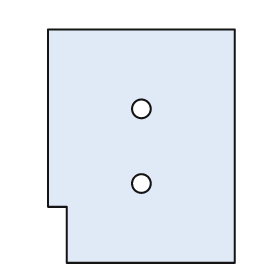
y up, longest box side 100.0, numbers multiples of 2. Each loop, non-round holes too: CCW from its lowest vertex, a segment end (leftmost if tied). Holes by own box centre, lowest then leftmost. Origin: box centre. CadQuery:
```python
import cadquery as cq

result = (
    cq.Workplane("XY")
    .moveTo(-32.0, -50.0)
    .lineTo(40.0, -50.0)
    .lineTo(40.0, 50.0)
    .lineTo(-40.0, 50.0)
    .lineTo(-40.0, -26.0)
    .lineTo(-32.0, -26.0)
    .close()
    .moveTo(0.0, -16.0)
    .circle(4.0)
    .moveTo(0.0, 16.0)
    .circle(4.0)
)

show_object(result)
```